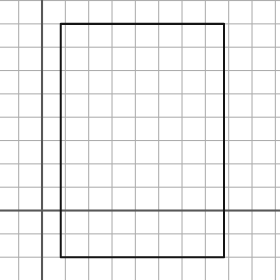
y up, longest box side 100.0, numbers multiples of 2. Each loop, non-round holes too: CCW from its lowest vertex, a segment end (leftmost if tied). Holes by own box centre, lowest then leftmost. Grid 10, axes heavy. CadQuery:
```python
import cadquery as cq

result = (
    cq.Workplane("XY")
    .moveTo(8.0, -20.0)
    .lineTo(78.0, -20.0)
    .lineTo(78.0, 80.0)
    .lineTo(8.0, 80.0)
    .close()
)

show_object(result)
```